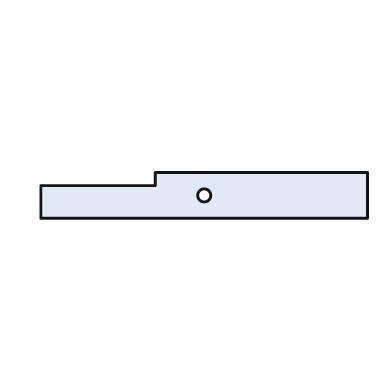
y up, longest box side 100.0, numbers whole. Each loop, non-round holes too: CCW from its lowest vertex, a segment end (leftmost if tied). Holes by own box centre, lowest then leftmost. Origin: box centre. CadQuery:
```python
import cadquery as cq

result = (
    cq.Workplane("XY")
    .moveTo(-50.0, -7.0)
    .lineTo(50.0, -7.0)
    .lineTo(50.0, 7.0)
    .lineTo(-15.0, 7.0)
    .lineTo(-15.0, 3.0)
    .lineTo(-50.0, 3.0)
    .close()
    .moveTo(0.0, 0.0)
    .circle(2.0)
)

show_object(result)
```